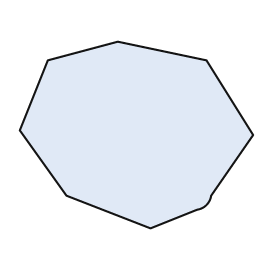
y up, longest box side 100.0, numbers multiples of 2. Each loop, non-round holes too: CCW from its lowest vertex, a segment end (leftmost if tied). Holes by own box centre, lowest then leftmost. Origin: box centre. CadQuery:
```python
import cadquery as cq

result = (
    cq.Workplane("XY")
    .moveTo(6.0, -40.0)
    .lineTo(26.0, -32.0)
    .threePointArc((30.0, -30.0), (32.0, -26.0))
    .lineTo(50.0, 0.0)
    .lineTo(30.0, 32.0)
    .lineTo(-8.0, 40.0)
    .lineTo(-38.0, 32.0)
    .lineTo(-50.0, 2.0)
    .lineTo(-30.0, -26.0)
    .close()
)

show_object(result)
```